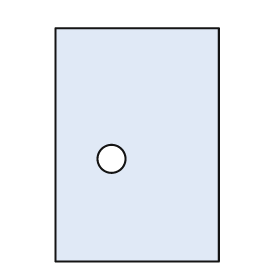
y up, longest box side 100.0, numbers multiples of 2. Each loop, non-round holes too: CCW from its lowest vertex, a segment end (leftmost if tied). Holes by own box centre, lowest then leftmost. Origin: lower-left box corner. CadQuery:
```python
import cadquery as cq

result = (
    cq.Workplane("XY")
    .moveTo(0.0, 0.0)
    .lineTo(70.0, 0.0)
    .lineTo(70.0, 100.0)
    .lineTo(0.0, 100.0)
    .close()
    .moveTo(24.0, 44.0)
    .circle(6.0)
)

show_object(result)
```